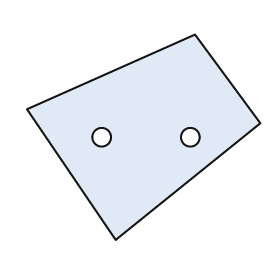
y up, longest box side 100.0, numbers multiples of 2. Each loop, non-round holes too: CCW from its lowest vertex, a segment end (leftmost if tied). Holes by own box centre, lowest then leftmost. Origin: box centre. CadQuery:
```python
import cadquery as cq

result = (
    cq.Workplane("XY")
    .moveTo(-12.0, -44.0)
    .lineTo(50.0, 6.0)
    .lineTo(22.0, 44.0)
    .lineTo(-50.0, 12.0)
    .close()
    .moveTo(-18.0, 0.0)
    .circle(4.0)
    .moveTo(20.0, 0.0)
    .circle(4.0)
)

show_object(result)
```